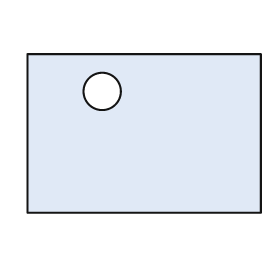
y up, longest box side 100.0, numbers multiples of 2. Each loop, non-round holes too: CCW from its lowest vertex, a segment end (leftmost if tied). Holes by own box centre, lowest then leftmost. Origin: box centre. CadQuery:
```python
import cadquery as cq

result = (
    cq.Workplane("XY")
    .moveTo(-50.0, -34.0)
    .lineTo(50.0, -34.0)
    .lineTo(50.0, 34.0)
    .lineTo(-50.0, 34.0)
    .close()
    .moveTo(-18.0, 18.0)
    .circle(8.0)
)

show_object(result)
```